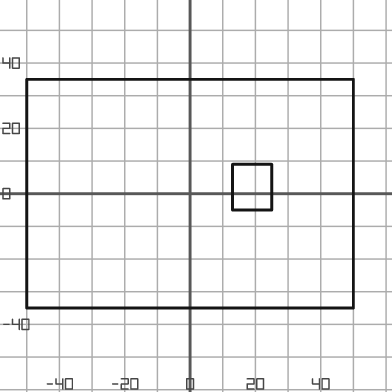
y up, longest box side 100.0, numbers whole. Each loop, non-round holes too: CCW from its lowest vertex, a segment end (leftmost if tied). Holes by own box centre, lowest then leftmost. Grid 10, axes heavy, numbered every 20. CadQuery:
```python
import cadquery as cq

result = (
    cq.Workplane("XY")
    .moveTo(-50.0, -35.0)
    .lineTo(50.0, -35.0)
    .lineTo(50.0, 35.0)
    .lineTo(-50.0, 35.0)
    .close()
    .moveTo(13.0, -5.0)
    .lineTo(25.0, -5.0)
    .lineTo(25.0, 9.0)
    .lineTo(13.0, 9.0)
    .close()
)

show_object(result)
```